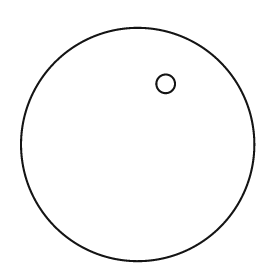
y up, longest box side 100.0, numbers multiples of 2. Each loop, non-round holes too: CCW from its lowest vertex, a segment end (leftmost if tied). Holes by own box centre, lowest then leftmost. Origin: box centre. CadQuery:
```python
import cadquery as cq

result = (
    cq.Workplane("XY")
    .moveTo(0.0, 0.0)
    .circle(50.0)
    .moveTo(12.0, 26.0)
    .circle(4.0)
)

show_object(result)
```